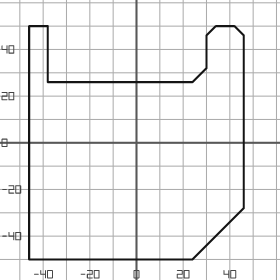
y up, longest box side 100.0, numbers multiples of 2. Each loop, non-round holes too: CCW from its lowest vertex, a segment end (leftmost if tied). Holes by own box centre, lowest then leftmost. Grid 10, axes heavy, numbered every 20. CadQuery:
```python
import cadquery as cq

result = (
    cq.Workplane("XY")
    .moveTo(-46.0, -50.0)
    .lineTo(24.0, -50.0)
    .lineTo(46.0, -28.0)
    .lineTo(46.0, 46.0)
    .lineTo(42.0, 50.0)
    .lineTo(34.0, 50.0)
    .lineTo(30.0, 46.0)
    .lineTo(30.0, 32.0)
    .lineTo(24.0, 26.0)
    .lineTo(-38.0, 26.0)
    .lineTo(-38.0, 50.0)
    .lineTo(-46.0, 50.0)
    .close()
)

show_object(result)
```